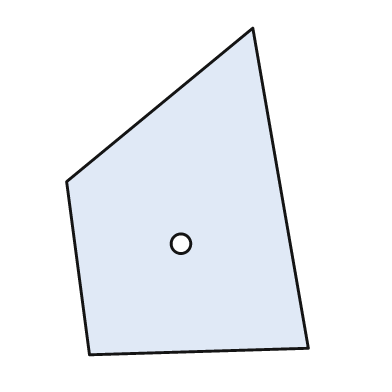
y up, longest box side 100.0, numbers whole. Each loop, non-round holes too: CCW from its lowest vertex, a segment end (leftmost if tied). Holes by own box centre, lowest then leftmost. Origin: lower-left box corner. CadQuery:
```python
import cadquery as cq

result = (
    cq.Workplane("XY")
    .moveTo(7.0, 0.0)
    .lineTo(74.0, 2.0)
    .lineTo(57.0, 100.0)
    .lineTo(0.0, 53.0)
    .close()
    .moveTo(35.0, 34.0)
    .circle(3.0)
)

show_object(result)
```